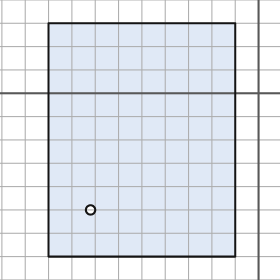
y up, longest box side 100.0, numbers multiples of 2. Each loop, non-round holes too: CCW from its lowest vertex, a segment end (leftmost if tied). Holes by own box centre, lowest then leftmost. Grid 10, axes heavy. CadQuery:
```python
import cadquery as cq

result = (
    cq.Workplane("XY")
    .moveTo(-90.0, -70.0)
    .lineTo(-10.0, -70.0)
    .lineTo(-10.0, 30.0)
    .lineTo(-90.0, 30.0)
    .close()
    .moveTo(-72.0, -50.0)
    .circle(2.0)
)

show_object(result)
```